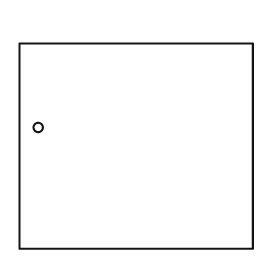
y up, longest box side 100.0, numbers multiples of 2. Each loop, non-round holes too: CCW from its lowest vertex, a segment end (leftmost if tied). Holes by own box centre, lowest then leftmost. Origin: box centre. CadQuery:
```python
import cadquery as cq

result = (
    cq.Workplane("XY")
    .moveTo(-50.0, -44.0)
    .lineTo(50.0, -44.0)
    .lineTo(50.0, 44.0)
    .lineTo(-50.0, 44.0)
    .close()
    .moveTo(-42.0, 8.0)
    .circle(2.0)
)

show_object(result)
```